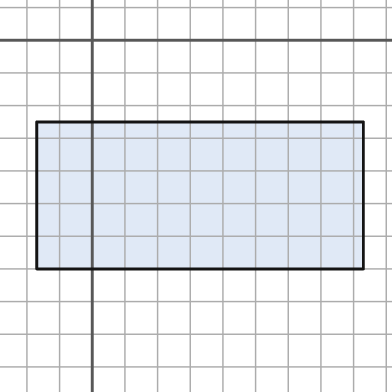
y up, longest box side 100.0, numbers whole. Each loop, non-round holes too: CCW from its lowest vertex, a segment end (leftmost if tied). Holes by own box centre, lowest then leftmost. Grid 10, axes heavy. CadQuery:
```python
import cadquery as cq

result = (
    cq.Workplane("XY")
    .moveTo(-17.0, -70.0)
    .lineTo(83.0, -70.0)
    .lineTo(83.0, -25.0)
    .lineTo(-17.0, -25.0)
    .close()
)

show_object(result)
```